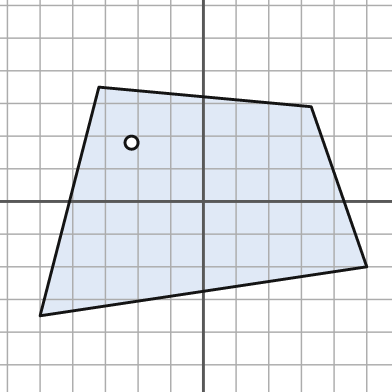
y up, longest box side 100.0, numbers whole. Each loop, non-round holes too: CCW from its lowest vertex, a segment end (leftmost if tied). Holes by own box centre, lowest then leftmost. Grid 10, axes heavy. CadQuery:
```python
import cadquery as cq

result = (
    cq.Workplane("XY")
    .moveTo(-50.0, -35.0)
    .lineTo(50.0, -20.0)
    .lineTo(33.0, 29.0)
    .lineTo(-32.0, 35.0)
    .close()
    .moveTo(-22.0, 18.0)
    .circle(2.0)
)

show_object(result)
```